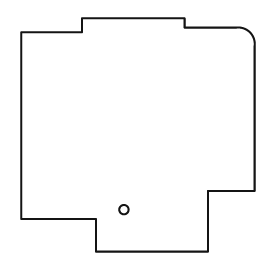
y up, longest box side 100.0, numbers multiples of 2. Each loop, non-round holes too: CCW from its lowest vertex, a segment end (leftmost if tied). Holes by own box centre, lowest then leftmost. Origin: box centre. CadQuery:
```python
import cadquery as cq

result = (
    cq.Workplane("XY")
    .moveTo(-18.0, -50.0)
    .lineTo(30.0, -50.0)
    .lineTo(30.0, -24.0)
    .lineTo(50.0, -24.0)
    .lineTo(50.0, 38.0)
    .threePointArc((48.0, 44.0), (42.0, 46.0))
    .lineTo(20.0, 46.0)
    .lineTo(20.0, 50.0)
    .lineTo(-24.0, 50.0)
    .lineTo(-24.0, 44.0)
    .lineTo(-50.0, 44.0)
    .lineTo(-50.0, -36.0)
    .lineTo(-18.0, -36.0)
    .close()
    .moveTo(-6.0, -32.0)
    .circle(2.0)
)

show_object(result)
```